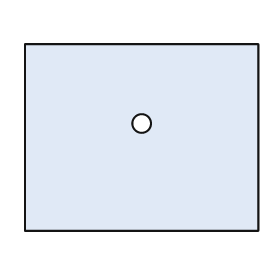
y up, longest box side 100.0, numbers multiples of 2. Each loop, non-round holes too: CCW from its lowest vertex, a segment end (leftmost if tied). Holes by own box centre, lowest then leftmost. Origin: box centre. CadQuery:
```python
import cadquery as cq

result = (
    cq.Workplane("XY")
    .moveTo(-50.0, -40.0)
    .lineTo(50.0, -40.0)
    .lineTo(50.0, 40.0)
    .lineTo(-50.0, 40.0)
    .close()
    .moveTo(0.0, 6.0)
    .circle(4.0)
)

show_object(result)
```